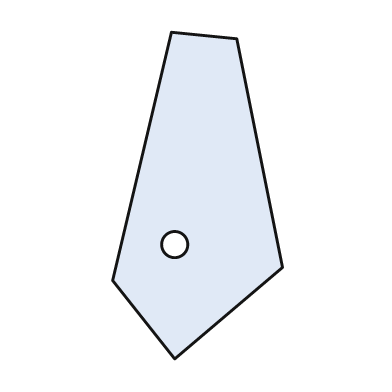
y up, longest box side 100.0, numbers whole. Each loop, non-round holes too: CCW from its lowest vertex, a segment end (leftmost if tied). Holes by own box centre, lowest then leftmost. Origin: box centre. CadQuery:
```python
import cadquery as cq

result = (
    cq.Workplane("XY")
    .moveTo(-7.0, -50.0)
    .lineTo(26.0, -22.0)
    .lineTo(12.0, 48.0)
    .lineTo(-8.0, 50.0)
    .lineTo(-26.0, -26.0)
    .close()
    .moveTo(-7.0, -15.0)
    .circle(4.0)
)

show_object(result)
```